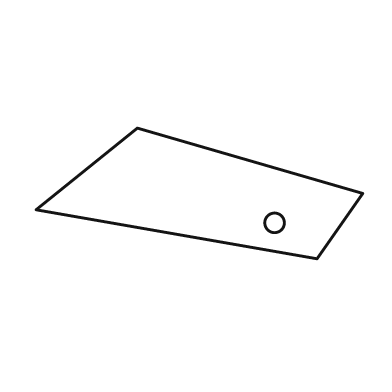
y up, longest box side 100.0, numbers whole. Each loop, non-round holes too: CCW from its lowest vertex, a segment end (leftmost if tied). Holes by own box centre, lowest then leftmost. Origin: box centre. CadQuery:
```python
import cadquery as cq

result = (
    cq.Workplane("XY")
    .moveTo(36.0, -20.0)
    .lineTo(50.0, 0.0)
    .lineTo(-19.0, 20.0)
    .lineTo(-50.0, -5.0)
    .close()
    .moveTo(23.0, -9.0)
    .circle(3.0)
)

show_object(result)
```